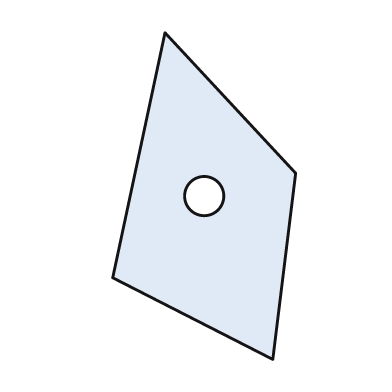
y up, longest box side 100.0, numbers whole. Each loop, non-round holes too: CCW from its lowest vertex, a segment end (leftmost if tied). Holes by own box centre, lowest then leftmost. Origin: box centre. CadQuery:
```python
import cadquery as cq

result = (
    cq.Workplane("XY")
    .moveTo(21.0, -50.0)
    .lineTo(28.0, 7.0)
    .lineTo(-12.0, 50.0)
    .lineTo(-28.0, -25.0)
    .close()
    .moveTo(0.0, 0.0)
    .circle(6.0)
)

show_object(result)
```